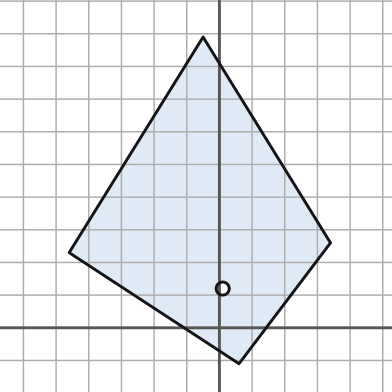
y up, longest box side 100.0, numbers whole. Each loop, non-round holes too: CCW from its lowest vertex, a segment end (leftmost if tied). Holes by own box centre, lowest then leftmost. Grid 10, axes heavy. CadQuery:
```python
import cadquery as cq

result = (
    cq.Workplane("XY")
    .moveTo(6.0, -11.0)
    .lineTo(34.0, 26.0)
    .lineTo(-5.0, 89.0)
    .lineTo(-46.0, 23.0)
    .close()
    .moveTo(1.0, 12.0)
    .circle(2.0)
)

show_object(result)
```